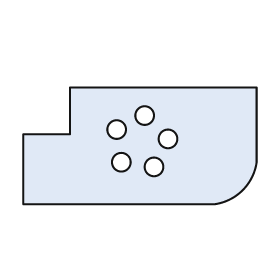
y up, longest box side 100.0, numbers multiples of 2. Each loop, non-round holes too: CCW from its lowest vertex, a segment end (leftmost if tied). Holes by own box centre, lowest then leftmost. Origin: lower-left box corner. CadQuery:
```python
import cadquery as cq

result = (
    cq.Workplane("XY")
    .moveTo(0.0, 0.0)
    .lineTo(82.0, 0.0)
    .threePointArc((94.0, 6.0), (100.0, 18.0))
    .lineTo(100.0, 50.0)
    .lineTo(20.0, 50.0)
    .lineTo(20.0, 30.0)
    .lineTo(0.0, 30.0)
    .close()
    .moveTo(56.0, 16.0)
    .circle(4.0)
    .moveTo(42.0, 18.0)
    .circle(4.0)
    .moveTo(62.0, 28.0)
    .circle(4.0)
    .moveTo(40.0, 32.0)
    .circle(4.0)
    .moveTo(52.0, 38.0)
    .circle(4.0)
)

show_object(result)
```